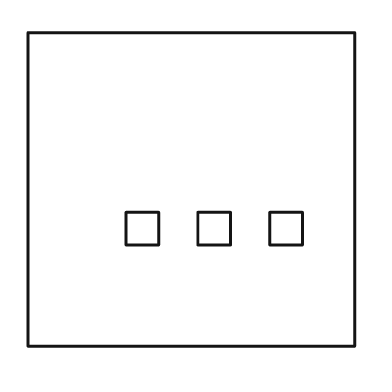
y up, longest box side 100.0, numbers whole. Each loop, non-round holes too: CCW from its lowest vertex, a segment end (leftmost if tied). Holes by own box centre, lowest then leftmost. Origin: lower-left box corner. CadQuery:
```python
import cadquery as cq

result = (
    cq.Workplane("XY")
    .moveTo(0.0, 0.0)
    .lineTo(100.0, 0.0)
    .lineTo(100.0, 96.0)
    .lineTo(0.0, 96.0)
    .close()
    .moveTo(30.0, 31.0)
    .lineTo(40.0, 31.0)
    .lineTo(40.0, 41.0)
    .lineTo(30.0, 41.0)
    .close()
    .moveTo(52.0, 31.0)
    .lineTo(62.0, 31.0)
    .lineTo(62.0, 41.0)
    .lineTo(52.0, 41.0)
    .close()
    .moveTo(74.0, 31.0)
    .lineTo(84.0, 31.0)
    .lineTo(84.0, 41.0)
    .lineTo(74.0, 41.0)
    .close()
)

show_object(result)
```